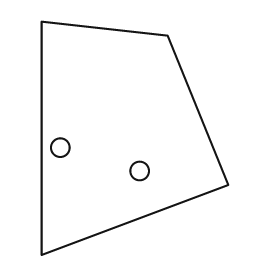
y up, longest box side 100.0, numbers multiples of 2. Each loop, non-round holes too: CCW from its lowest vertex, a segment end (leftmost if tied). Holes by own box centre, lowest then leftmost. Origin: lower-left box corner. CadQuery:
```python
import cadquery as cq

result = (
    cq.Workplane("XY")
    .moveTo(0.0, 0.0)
    .lineTo(80.0, 30.0)
    .lineTo(54.0, 94.0)
    .lineTo(0.0, 100.0)
    .close()
    .moveTo(42.0, 36.0)
    .circle(4.0)
    .moveTo(8.0, 46.0)
    .circle(4.0)
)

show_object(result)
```